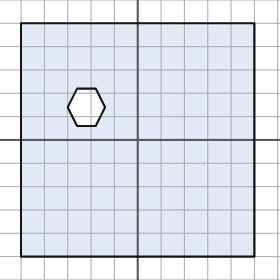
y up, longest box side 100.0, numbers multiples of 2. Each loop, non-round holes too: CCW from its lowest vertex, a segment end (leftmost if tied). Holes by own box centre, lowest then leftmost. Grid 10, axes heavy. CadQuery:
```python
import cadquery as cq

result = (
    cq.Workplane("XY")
    .moveTo(-50.0, -50.0)
    .lineTo(50.0, -50.0)
    .lineTo(50.0, 50.0)
    .lineTo(-50.0, 50.0)
    .close()
    .moveTo(-26.0, 6.0)
    .lineTo(-18.0, 6.0)
    .lineTo(-14.0, 14.0)
    .lineTo(-18.0, 22.0)
    .lineTo(-26.0, 22.0)
    .lineTo(-30.0, 14.0)
    .close()
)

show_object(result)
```